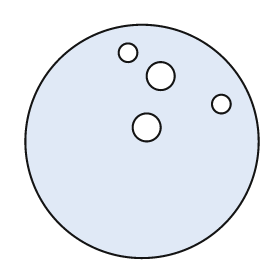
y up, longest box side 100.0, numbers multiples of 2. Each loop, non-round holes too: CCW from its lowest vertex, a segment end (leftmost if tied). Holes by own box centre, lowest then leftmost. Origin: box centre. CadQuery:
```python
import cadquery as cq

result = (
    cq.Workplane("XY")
    .moveTo(0.0, 0.0)
    .circle(50.0)
    .moveTo(2.0, 6.0)
    .circle(6.0)
    .moveTo(34.0, 16.0)
    .circle(4.0)
    .moveTo(8.0, 28.0)
    .circle(6.0)
    .moveTo(-6.0, 38.0)
    .circle(4.0)
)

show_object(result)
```